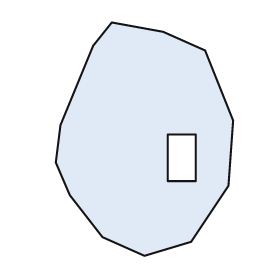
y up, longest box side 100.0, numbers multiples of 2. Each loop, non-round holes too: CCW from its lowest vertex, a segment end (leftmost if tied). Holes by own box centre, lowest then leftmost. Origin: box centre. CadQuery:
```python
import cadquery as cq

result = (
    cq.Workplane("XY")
    .moveTo(0.0, -50.0)
    .lineTo(20.0, -44.0)
    .lineTo(36.0, -20.0)
    .lineTo(38.0, 8.0)
    .lineTo(26.0, 38.0)
    .lineTo(8.0, 46.0)
    .lineTo(-14.0, 50.0)
    .lineTo(-22.0, 40.0)
    .lineTo(-36.0, 6.0)
    .lineTo(-38.0, -10.0)
    .lineTo(-32.0, -24.0)
    .lineTo(-18.0, -42.0)
    .close()
    .moveTo(10.0, -18.0)
    .lineTo(22.0, -18.0)
    .lineTo(22.0, 2.0)
    .lineTo(10.0, 2.0)
    .close()
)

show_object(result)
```